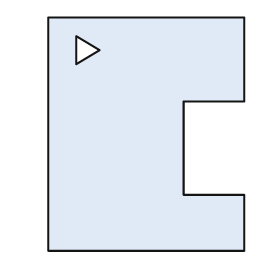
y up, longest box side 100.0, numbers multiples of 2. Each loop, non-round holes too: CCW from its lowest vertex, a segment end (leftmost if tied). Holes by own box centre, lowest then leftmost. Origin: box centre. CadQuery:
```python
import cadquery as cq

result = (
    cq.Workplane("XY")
    .moveTo(-42.0, -50.0)
    .lineTo(42.0, -50.0)
    .lineTo(42.0, -26.0)
    .lineTo(16.0, -26.0)
    .lineTo(16.0, 14.0)
    .lineTo(42.0, 14.0)
    .lineTo(42.0, 50.0)
    .lineTo(-42.0, 50.0)
    .close()
    .moveTo(-30.0, 30.0)
    .lineTo(-20.0, 36.0)
    .lineTo(-30.0, 42.0)
    .close()
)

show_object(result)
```